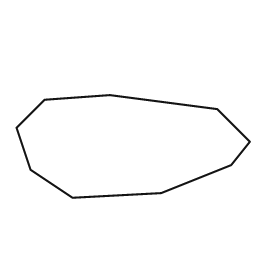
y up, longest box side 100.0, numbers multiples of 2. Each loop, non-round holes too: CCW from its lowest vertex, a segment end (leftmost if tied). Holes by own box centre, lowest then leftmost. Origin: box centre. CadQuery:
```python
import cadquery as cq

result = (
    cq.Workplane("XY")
    .moveTo(-26.0, -22.0)
    .lineTo(12.0, -20.0)
    .lineTo(42.0, -8.0)
    .lineTo(50.0, 2.0)
    .lineTo(36.0, 16.0)
    .lineTo(-10.0, 22.0)
    .lineTo(-38.0, 20.0)
    .lineTo(-50.0, 8.0)
    .lineTo(-44.0, -10.0)
    .close()
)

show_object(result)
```